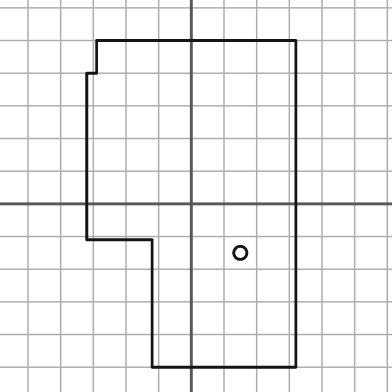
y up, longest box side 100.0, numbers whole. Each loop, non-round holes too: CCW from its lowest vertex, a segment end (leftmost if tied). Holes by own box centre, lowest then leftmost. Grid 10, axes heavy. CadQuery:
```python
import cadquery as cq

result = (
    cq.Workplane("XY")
    .moveTo(-12.0, -50.0)
    .lineTo(32.0, -50.0)
    .lineTo(32.0, 50.0)
    .lineTo(-29.0, 50.0)
    .lineTo(-29.0, 40.0)
    .lineTo(-32.0, 40.0)
    .lineTo(-32.0, -11.0)
    .lineTo(-12.0, -11.0)
    .close()
    .moveTo(15.0, -15.0)
    .circle(2.0)
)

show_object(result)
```